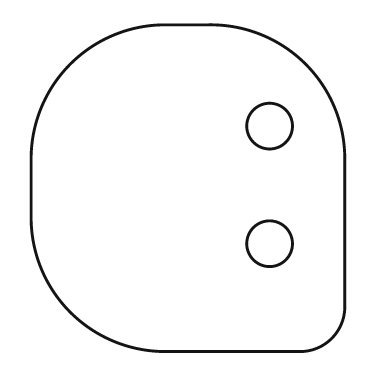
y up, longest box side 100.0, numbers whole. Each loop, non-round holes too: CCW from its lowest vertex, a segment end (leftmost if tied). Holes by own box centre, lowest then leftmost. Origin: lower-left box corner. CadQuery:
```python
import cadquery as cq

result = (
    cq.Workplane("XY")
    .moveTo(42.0, 0.0)
    .lineTo(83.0, 0.0)
    .threePointArc((92.0, 4.0), (96.0, 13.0))
    .lineTo(96.0, 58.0)
    .threePointArc((84.0, 88.0), (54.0, 100.0))
    .lineTo(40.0, 100.0)
    .threePointArc((12.0, 88.0), (0.0, 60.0))
    .lineTo(0.0, 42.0)
    .threePointArc((12.0, 12.0), (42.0, 0.0))
    .close()
    .moveTo(73.0, 33.0)
    .circle(7.0)
    .moveTo(73.0, 69.0)
    .circle(7.0)
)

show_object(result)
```